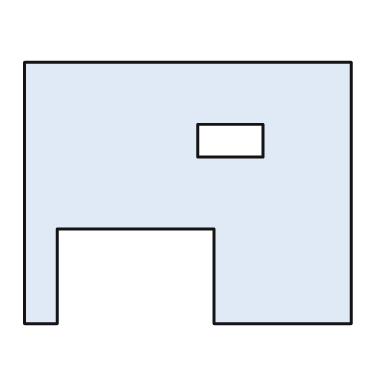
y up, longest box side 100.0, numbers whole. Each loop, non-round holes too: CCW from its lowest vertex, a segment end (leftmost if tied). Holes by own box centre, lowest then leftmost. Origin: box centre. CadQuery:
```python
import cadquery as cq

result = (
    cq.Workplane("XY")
    .moveTo(-50.0, -40.0)
    .lineTo(-40.0, -40.0)
    .lineTo(-40.0, -11.0)
    .lineTo(8.0, -11.0)
    .lineTo(8.0, -40.0)
    .lineTo(50.0, -40.0)
    .lineTo(50.0, 40.0)
    .lineTo(-50.0, 40.0)
    .close()
    .moveTo(3.0, 11.0)
    .lineTo(23.0, 11.0)
    .lineTo(23.0, 21.0)
    .lineTo(3.0, 21.0)
    .close()
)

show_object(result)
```